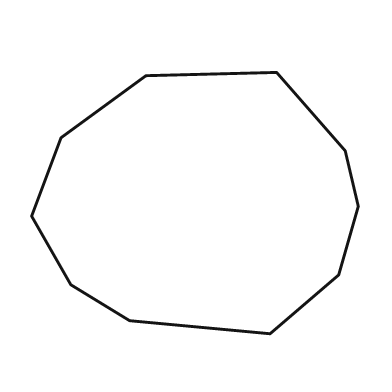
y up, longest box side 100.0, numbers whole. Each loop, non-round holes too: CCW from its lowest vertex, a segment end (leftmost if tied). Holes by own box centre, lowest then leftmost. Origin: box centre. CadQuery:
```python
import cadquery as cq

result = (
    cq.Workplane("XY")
    .moveTo(23.0, -40.0)
    .lineTo(44.0, -22.0)
    .lineTo(50.0, -1.0)
    .lineTo(46.0, 16.0)
    .lineTo(25.0, 40.0)
    .lineTo(-15.0, 39.0)
    .lineTo(-41.0, 20.0)
    .lineTo(-50.0, -4.0)
    .lineTo(-38.0, -25.0)
    .lineTo(-20.0, -36.0)
    .close()
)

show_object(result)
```